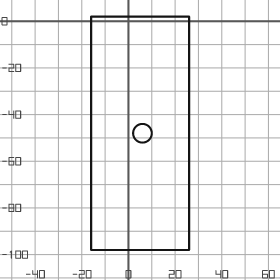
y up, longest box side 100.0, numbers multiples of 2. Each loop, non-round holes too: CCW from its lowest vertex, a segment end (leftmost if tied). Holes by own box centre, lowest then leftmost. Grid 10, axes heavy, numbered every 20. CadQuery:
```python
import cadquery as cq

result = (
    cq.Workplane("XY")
    .moveTo(-16.0, -98.0)
    .lineTo(26.0, -98.0)
    .lineTo(26.0, 2.0)
    .lineTo(-16.0, 2.0)
    .close()
    .moveTo(6.0, -48.0)
    .circle(4.0)
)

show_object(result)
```